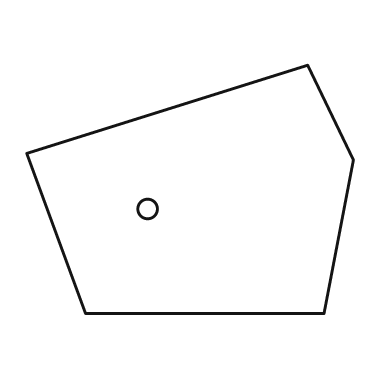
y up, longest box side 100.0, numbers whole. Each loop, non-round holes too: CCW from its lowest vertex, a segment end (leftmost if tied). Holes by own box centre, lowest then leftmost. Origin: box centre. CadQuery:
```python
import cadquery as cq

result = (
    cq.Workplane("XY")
    .moveTo(-32.0, -38.0)
    .lineTo(41.0, -38.0)
    .lineTo(50.0, 9.0)
    .lineTo(36.0, 38.0)
    .lineTo(-50.0, 11.0)
    .close()
    .moveTo(-13.0, -6.0)
    .circle(3.0)
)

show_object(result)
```